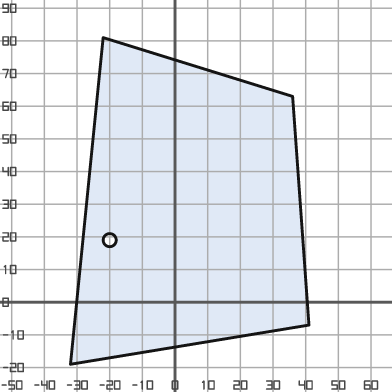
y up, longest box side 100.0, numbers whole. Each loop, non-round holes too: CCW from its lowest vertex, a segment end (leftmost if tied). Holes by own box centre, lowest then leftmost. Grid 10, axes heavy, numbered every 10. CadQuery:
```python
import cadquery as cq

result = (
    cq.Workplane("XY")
    .moveTo(-32.0, -19.0)
    .lineTo(41.0, -7.0)
    .lineTo(36.0, 63.0)
    .lineTo(-22.0, 81.0)
    .close()
    .moveTo(-20.0, 19.0)
    .circle(2.0)
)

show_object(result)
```